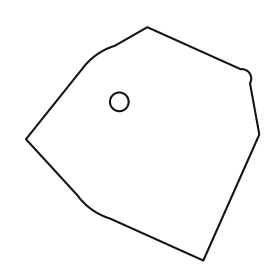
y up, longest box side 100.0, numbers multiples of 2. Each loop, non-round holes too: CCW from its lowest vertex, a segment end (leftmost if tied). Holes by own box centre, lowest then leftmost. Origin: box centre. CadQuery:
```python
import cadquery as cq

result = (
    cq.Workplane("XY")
    .moveTo(26.0, -50.0)
    .lineTo(50.0, 4.0)
    .lineTo(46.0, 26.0)
    .threePointArc((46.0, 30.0), (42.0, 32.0))
    .lineTo(2.0, 50.0)
    .lineTo(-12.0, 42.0)
    .threePointArc((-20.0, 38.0), (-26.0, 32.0))
    .lineTo(-50.0, 2.0)
    .lineTo(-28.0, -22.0)
    .threePointArc((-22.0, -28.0), (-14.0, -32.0))
    .close()
    .moveTo(-10.0, 18.0)
    .circle(4.0)
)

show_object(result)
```